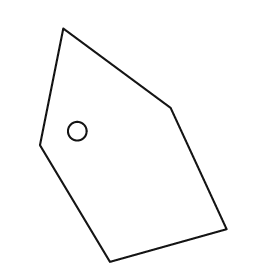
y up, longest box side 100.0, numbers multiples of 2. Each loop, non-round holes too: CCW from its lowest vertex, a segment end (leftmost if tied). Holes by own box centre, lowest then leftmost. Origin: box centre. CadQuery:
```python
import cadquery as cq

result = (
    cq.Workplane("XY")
    .moveTo(-10.0, -50.0)
    .lineTo(40.0, -36.0)
    .lineTo(16.0, 16.0)
    .lineTo(-30.0, 50.0)
    .lineTo(-40.0, 0.0)
    .close()
    .moveTo(-24.0, 6.0)
    .circle(4.0)
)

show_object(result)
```